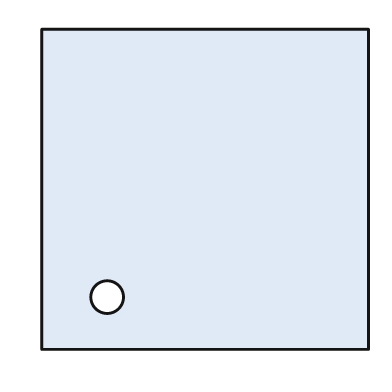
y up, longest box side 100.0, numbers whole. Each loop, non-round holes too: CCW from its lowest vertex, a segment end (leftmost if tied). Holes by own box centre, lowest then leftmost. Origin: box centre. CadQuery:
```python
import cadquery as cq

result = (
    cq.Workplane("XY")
    .moveTo(-50.0, -49.0)
    .lineTo(50.0, -49.0)
    .lineTo(50.0, 49.0)
    .lineTo(-50.0, 49.0)
    .close()
    .moveTo(-30.0, -33.0)
    .circle(5.0)
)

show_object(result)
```